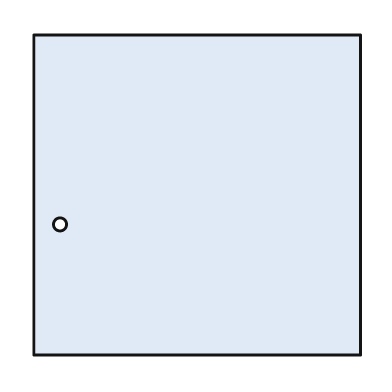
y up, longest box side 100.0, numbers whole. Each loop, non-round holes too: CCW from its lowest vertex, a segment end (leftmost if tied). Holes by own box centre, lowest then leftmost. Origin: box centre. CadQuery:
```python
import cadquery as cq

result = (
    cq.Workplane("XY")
    .moveTo(-50.0, -49.0)
    .lineTo(50.0, -49.0)
    .lineTo(50.0, 49.0)
    .lineTo(-50.0, 49.0)
    .close()
    .moveTo(-42.0, -9.0)
    .circle(2.0)
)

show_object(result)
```